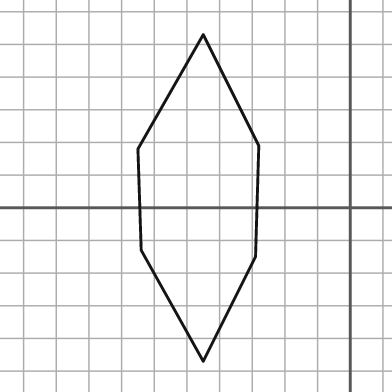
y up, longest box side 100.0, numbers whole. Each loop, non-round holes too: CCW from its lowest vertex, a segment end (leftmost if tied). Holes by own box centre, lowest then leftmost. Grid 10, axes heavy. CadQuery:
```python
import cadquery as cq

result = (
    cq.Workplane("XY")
    .moveTo(-45.0, -47.0)
    .lineTo(-29.0, -15.0)
    .lineTo(-28.0, 19.0)
    .lineTo(-45.0, 53.0)
    .lineTo(-65.0, 18.0)
    .lineTo(-64.0, -13.0)
    .close()
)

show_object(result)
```